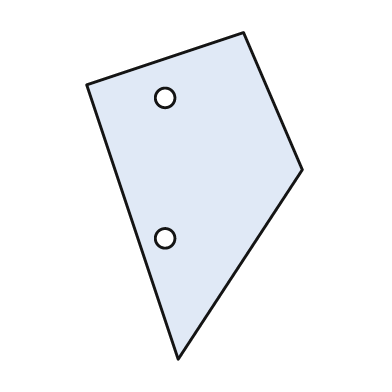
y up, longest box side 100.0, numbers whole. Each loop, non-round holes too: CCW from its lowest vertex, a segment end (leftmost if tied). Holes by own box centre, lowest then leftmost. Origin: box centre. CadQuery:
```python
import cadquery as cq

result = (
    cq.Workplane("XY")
    .moveTo(-5.0, -50.0)
    .lineTo(33.0, 8.0)
    .lineTo(15.0, 50.0)
    .lineTo(-33.0, 34.0)
    .close()
    .moveTo(-9.0, -13.0)
    .circle(3.0)
    .moveTo(-9.0, 30.0)
    .circle(3.0)
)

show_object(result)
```